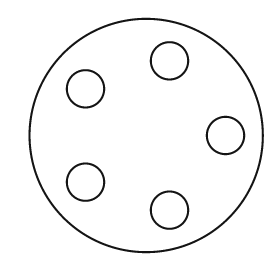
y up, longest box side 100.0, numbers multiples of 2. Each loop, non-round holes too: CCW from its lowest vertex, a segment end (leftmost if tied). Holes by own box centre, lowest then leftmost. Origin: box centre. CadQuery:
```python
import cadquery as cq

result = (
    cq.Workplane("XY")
    .moveTo(0.0, 0.0)
    .circle(50.0)
    .moveTo(10.0, -32.0)
    .circle(8.0)
    .moveTo(-26.0, -20.0)
    .circle(8.0)
    .moveTo(34.0, 0.0)
    .circle(8.0)
    .moveTo(-26.0, 20.0)
    .circle(8.0)
    .moveTo(10.0, 32.0)
    .circle(8.0)
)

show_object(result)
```